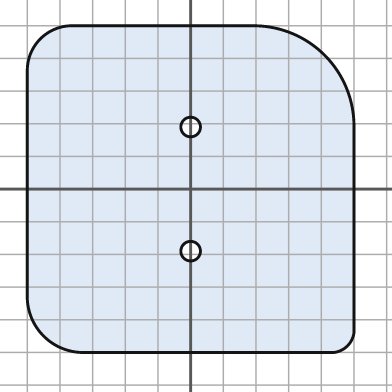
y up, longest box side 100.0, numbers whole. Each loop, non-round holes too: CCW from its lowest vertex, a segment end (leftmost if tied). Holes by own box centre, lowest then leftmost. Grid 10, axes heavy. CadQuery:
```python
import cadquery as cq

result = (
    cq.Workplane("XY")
    .moveTo(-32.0, -50.0)
    .lineTo(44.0, -50.0)
    .threePointArc((48.0, -48.0), (50.0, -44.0))
    .lineTo(50.0, 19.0)
    .threePointArc((41.0, 41.0), (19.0, 50.0))
    .lineTo(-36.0, 50.0)
    .threePointArc((-46.0, 46.0), (-50.0, 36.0))
    .lineTo(-50.0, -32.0)
    .threePointArc((-45.0, -45.0), (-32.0, -50.0))
    .close()
    .moveTo(0.0, -19.0)
    .circle(3.0)
    .moveTo(0.0, 19.0)
    .circle(3.0)
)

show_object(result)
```